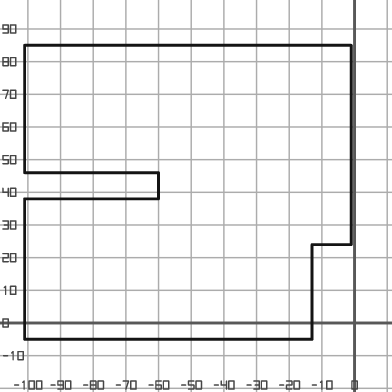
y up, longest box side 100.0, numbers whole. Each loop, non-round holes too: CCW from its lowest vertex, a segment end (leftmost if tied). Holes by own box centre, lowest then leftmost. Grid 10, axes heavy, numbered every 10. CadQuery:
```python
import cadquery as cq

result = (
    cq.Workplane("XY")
    .moveTo(-101.0, -5.0)
    .lineTo(-13.0, -5.0)
    .lineTo(-13.0, 24.0)
    .lineTo(-1.0, 24.0)
    .lineTo(-1.0, 85.0)
    .lineTo(-101.0, 85.0)
    .lineTo(-101.0, 46.0)
    .lineTo(-60.0, 46.0)
    .lineTo(-60.0, 38.0)
    .lineTo(-101.0, 38.0)
    .close()
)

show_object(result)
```